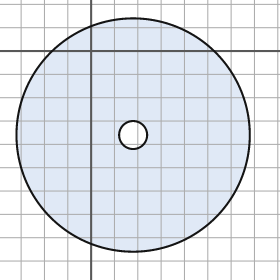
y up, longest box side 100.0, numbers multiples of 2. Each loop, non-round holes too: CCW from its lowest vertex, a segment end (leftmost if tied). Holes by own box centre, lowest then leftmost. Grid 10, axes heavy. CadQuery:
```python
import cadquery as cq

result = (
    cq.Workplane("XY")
    .moveTo(18.0, -36.0)
    .circle(50.0)
    .moveTo(18.0, -36.0)
    .circle(6.0)
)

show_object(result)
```